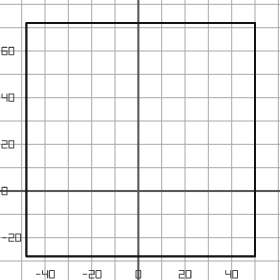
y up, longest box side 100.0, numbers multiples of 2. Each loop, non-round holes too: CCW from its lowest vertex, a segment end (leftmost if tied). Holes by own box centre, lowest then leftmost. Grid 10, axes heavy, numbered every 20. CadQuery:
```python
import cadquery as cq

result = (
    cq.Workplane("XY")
    .moveTo(-48.0, -28.0)
    .lineTo(50.0, -28.0)
    .lineTo(50.0, 72.0)
    .lineTo(-48.0, 72.0)
    .close()
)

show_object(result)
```